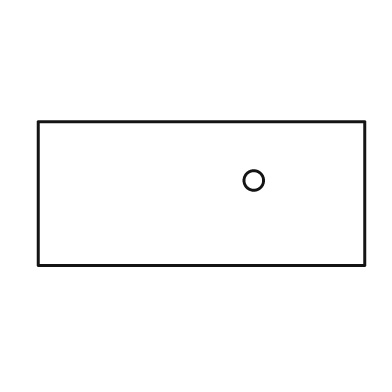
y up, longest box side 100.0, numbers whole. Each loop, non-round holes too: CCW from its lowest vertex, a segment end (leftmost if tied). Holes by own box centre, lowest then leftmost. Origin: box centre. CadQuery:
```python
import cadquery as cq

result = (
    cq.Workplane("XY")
    .moveTo(-50.0, -22.0)
    .lineTo(50.0, -22.0)
    .lineTo(50.0, 22.0)
    .lineTo(-50.0, 22.0)
    .close()
    .moveTo(16.0, 4.0)
    .circle(3.0)
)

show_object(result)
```